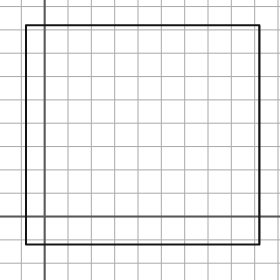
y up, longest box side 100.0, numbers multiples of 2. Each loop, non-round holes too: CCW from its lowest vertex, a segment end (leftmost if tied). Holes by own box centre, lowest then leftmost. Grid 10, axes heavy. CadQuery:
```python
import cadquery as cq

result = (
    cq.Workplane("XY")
    .moveTo(-8.0, -12.0)
    .lineTo(92.0, -12.0)
    .lineTo(92.0, 82.0)
    .lineTo(-8.0, 82.0)
    .close()
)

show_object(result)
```